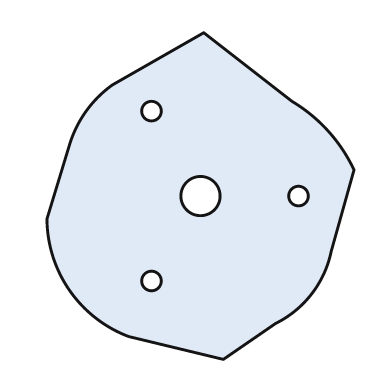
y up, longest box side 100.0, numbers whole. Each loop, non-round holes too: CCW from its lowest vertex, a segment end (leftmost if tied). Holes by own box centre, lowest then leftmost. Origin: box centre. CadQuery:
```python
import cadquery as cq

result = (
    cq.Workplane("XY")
    .moveTo(7.0, -50.0)
    .lineTo(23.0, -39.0)
    .threePointArc((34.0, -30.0), (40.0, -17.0))
    .lineTo(47.0, 8.0)
    .threePointArc((39.0, 20.0), (28.0, 29.0))
    .lineTo(1.0, 50.0)
    .lineTo(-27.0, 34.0)
    .threePointArc((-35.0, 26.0), (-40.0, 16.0))
    .lineTo(-47.0, -7.0)
    .threePointArc((-40.0, -29.0), (-22.0, -43.0))
    .close()
    .moveTo(-15.0, -26.0)
    .circle(3.0)
    .moveTo(0.0, 0.0)
    .circle(6.0)
    .moveTo(30.0, 0.0)
    .circle(3.0)
    .moveTo(-15.0, 26.0)
    .circle(3.0)
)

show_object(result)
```